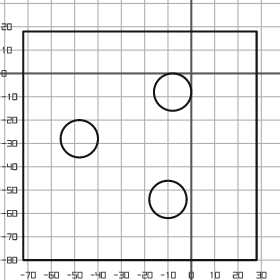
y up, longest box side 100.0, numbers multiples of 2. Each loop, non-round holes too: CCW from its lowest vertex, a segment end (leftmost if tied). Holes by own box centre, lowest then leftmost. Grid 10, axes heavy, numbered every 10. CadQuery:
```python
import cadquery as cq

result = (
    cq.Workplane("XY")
    .moveTo(-72.0, -80.0)
    .lineTo(28.0, -80.0)
    .lineTo(28.0, 18.0)
    .lineTo(-72.0, 18.0)
    .close()
    .moveTo(-10.0, -54.0)
    .circle(8.0)
    .moveTo(-48.0, -28.0)
    .circle(8.0)
    .moveTo(-8.0, -8.0)
    .circle(8.0)
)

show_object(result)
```